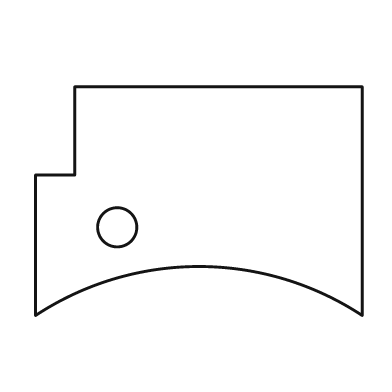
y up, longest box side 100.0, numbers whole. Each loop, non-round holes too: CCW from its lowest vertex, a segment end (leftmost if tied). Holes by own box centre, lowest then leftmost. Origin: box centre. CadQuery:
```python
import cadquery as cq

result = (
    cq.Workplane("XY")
    .moveTo(-50.0, -35.0)
    .threePointArc((0.0, -20.0), (50.0, -35.0))
    .lineTo(50.0, 35.0)
    .lineTo(-38.0, 35.0)
    .lineTo(-38.0, 8.0)
    .lineTo(-50.0, 8.0)
    .close()
    .moveTo(-25.0, -8.0)
    .circle(6.0)
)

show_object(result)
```